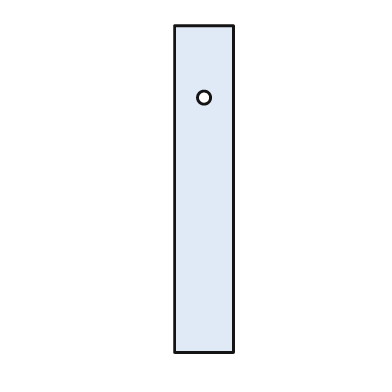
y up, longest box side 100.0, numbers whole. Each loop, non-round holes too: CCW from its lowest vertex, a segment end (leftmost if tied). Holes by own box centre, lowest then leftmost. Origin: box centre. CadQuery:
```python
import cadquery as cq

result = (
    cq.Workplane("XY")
    .moveTo(-9.0, -50.0)
    .lineTo(9.0, -50.0)
    .lineTo(9.0, 50.0)
    .lineTo(-9.0, 50.0)
    .close()
    .moveTo(0.0, 28.0)
    .circle(2.0)
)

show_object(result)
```